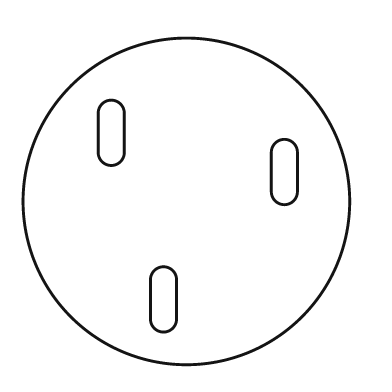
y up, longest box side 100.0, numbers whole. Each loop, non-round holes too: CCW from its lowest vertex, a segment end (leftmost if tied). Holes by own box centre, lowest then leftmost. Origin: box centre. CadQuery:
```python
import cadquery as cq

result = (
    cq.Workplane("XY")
    .moveTo(0.0, 0.0)
    .circle(50.0)
    .moveTo(-11.0, -36.0)
    .threePointArc((-7.0, -40.0), (-3.0, -36.0))
    .lineTo(-3.0, -24.0)
    .threePointArc((-7.0, -20.0), (-11.0, -24.0))
    .close()
    .moveTo(26.0, 3.0)
    .threePointArc((30.0, -1.0), (34.0, 3.0))
    .lineTo(34.0, 15.0)
    .threePointArc((30.0, 19.0), (26.0, 15.0))
    .close()
    .moveTo(-27.0, 15.0)
    .threePointArc((-23.0, 11.0), (-19.0, 15.0))
    .lineTo(-19.0, 27.0)
    .threePointArc((-23.0, 31.0), (-27.0, 27.0))
    .close()
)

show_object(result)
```